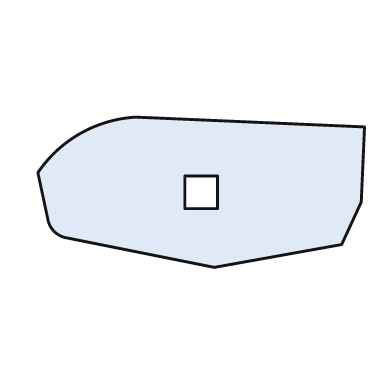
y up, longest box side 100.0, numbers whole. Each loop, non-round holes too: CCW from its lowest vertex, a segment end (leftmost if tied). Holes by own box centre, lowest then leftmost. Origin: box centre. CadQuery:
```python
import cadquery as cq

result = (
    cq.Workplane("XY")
    .moveTo(4.0, -23.0)
    .lineTo(43.0, -16.0)
    .lineTo(49.0, -3.0)
    .lineTo(50.0, 20.0)
    .lineTo(-20.0, 23.0)
    .threePointArc((-37.0, 18.0), (-50.0, 6.0))
    .lineTo(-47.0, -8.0)
    .threePointArc((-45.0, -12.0), (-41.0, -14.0))
    .close()
    .moveTo(-5.0, -5.0)
    .lineTo(5.0, -5.0)
    .lineTo(5.0, 5.0)
    .lineTo(-5.0, 5.0)
    .close()
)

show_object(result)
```